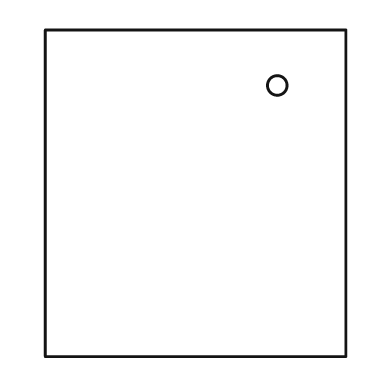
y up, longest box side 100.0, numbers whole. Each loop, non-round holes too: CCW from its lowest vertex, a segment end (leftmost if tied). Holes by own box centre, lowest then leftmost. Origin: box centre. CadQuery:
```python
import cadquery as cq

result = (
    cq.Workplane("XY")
    .moveTo(-46.0, -50.0)
    .lineTo(46.0, -50.0)
    .lineTo(46.0, 50.0)
    .lineTo(-46.0, 50.0)
    .close()
    .moveTo(25.0, 33.0)
    .circle(3.0)
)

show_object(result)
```